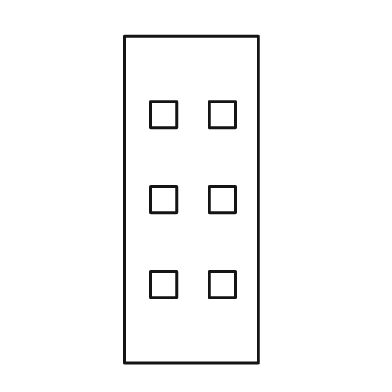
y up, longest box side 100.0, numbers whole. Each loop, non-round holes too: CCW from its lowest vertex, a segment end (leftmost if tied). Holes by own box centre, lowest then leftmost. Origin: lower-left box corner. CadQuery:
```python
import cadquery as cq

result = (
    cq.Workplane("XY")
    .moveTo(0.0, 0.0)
    .lineTo(41.0, 0.0)
    .lineTo(41.0, 100.0)
    .lineTo(0.0, 100.0)
    .close()
    .moveTo(8.0, 20.0)
    .lineTo(16.0, 20.0)
    .lineTo(16.0, 28.0)
    .lineTo(8.0, 28.0)
    .close()
    .moveTo(26.0, 20.0)
    .lineTo(34.0, 20.0)
    .lineTo(34.0, 28.0)
    .lineTo(26.0, 28.0)
    .close()
    .moveTo(8.0, 46.0)
    .lineTo(16.0, 46.0)
    .lineTo(16.0, 54.0)
    .lineTo(8.0, 54.0)
    .close()
    .moveTo(26.0, 46.0)
    .lineTo(34.0, 46.0)
    .lineTo(34.0, 54.0)
    .lineTo(26.0, 54.0)
    .close()
    .moveTo(8.0, 72.0)
    .lineTo(16.0, 72.0)
    .lineTo(16.0, 80.0)
    .lineTo(8.0, 80.0)
    .close()
    .moveTo(26.0, 72.0)
    .lineTo(34.0, 72.0)
    .lineTo(34.0, 80.0)
    .lineTo(26.0, 80.0)
    .close()
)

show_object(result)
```